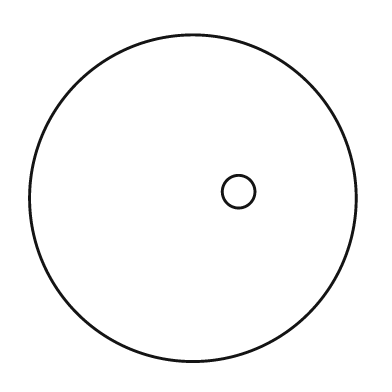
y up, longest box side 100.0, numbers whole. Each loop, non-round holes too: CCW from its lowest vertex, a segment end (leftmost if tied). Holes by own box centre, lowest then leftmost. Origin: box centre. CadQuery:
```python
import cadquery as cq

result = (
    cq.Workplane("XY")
    .moveTo(0.0, 0.0)
    .circle(50.0)
    .moveTo(14.0, 2.0)
    .circle(5.0)
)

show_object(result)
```